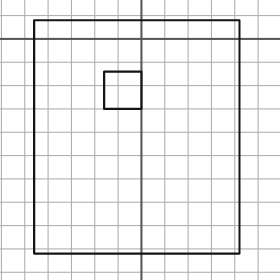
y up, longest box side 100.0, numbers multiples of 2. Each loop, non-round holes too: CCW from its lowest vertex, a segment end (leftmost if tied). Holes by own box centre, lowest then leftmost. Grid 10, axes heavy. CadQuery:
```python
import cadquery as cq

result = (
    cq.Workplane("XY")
    .moveTo(-46.0, -92.0)
    .lineTo(42.0, -92.0)
    .lineTo(42.0, 8.0)
    .lineTo(-46.0, 8.0)
    .close()
    .moveTo(-16.0, -30.0)
    .lineTo(0.0, -30.0)
    .lineTo(0.0, -14.0)
    .lineTo(-16.0, -14.0)
    .close()
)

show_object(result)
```